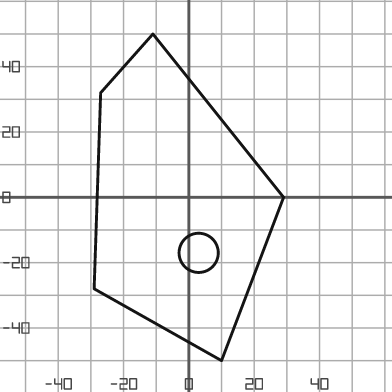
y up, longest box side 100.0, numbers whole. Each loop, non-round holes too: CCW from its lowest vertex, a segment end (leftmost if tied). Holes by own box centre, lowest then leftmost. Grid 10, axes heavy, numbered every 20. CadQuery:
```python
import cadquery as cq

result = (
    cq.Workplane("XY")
    .moveTo(10.0, -50.0)
    .lineTo(29.0, 0.0)
    .lineTo(-11.0, 50.0)
    .lineTo(-27.0, 32.0)
    .lineTo(-29.0, -28.0)
    .close()
    .moveTo(3.0, -17.0)
    .circle(6.0)
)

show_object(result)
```